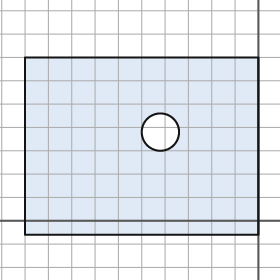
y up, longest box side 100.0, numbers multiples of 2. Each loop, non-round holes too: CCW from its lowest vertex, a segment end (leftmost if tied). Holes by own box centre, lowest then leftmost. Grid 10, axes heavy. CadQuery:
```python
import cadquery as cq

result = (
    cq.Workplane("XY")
    .moveTo(-100.0, -6.0)
    .lineTo(0.0, -6.0)
    .lineTo(0.0, 70.0)
    .lineTo(-100.0, 70.0)
    .close()
    .moveTo(-42.0, 38.0)
    .circle(8.0)
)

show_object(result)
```